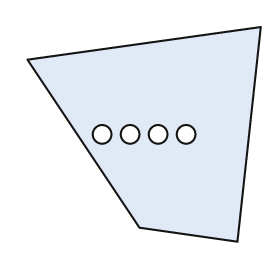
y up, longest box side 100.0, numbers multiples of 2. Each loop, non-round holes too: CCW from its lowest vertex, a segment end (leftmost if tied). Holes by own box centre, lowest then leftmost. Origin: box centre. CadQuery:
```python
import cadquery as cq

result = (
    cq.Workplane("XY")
    .moveTo(40.0, -46.0)
    .lineTo(50.0, 46.0)
    .lineTo(-50.0, 32.0)
    .lineTo(-2.0, -40.0)
    .close()
    .moveTo(-18.0, 0.0)
    .circle(4.0)
    .moveTo(-6.0, 0.0)
    .circle(4.0)
    .moveTo(6.0, 0.0)
    .circle(4.0)
    .moveTo(18.0, 0.0)
    .circle(4.0)
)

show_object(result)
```